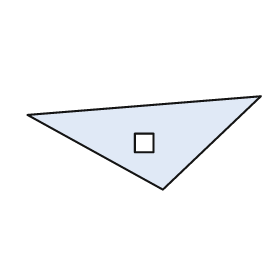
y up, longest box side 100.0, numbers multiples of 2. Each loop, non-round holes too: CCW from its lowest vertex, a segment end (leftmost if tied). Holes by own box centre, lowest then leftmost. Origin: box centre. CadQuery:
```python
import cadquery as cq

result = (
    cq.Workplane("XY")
    .moveTo(8.0, -20.0)
    .lineTo(50.0, 20.0)
    .lineTo(-50.0, 12.0)
    .close()
    .moveTo(-4.0, -4.0)
    .lineTo(4.0, -4.0)
    .lineTo(4.0, 4.0)
    .lineTo(-4.0, 4.0)
    .close()
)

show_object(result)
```